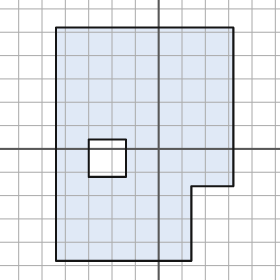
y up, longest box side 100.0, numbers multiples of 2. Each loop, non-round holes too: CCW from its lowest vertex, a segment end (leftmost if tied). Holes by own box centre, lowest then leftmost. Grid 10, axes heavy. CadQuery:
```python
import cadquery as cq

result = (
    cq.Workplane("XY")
    .moveTo(-44.0, -48.0)
    .lineTo(14.0, -48.0)
    .lineTo(14.0, -16.0)
    .lineTo(32.0, -16.0)
    .lineTo(32.0, 52.0)
    .lineTo(-44.0, 52.0)
    .close()
    .moveTo(-30.0, -12.0)
    .lineTo(-14.0, -12.0)
    .lineTo(-14.0, 4.0)
    .lineTo(-30.0, 4.0)
    .close()
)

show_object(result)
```